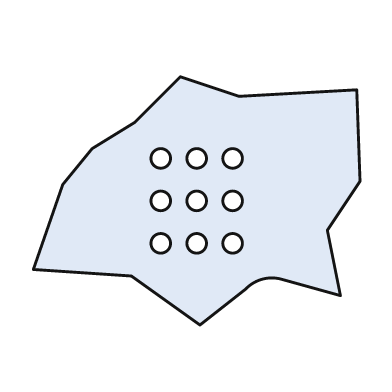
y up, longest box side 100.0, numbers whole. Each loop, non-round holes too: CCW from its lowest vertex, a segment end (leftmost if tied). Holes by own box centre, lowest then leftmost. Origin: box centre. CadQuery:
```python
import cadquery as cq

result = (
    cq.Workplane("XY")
    .moveTo(1.0, -38.0)
    .lineTo(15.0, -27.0)
    .threePointArc((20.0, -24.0), (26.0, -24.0))
    .lineTo(44.0, -29.0)
    .lineTo(40.0, -9.0)
    .lineTo(50.0, 6.0)
    .lineTo(49.0, 34.0)
    .lineTo(13.0, 32.0)
    .lineTo(-5.0, 38.0)
    .lineTo(-19.0, 24.0)
    .lineTo(-32.0, 16.0)
    .lineTo(-41.0, 5.0)
    .lineTo(-50.0, -21.0)
    .lineTo(-20.0, -23.0)
    .close()
    .moveTo(-11.0, -13.0)
    .circle(3.0)
    .moveTo(0.0, -13.0)
    .circle(3.0)
    .moveTo(11.0, -13.0)
    .circle(3.0)
    .moveTo(-11.0, 0.0)
    .circle(3.0)
    .moveTo(0.0, 0.0)
    .circle(3.0)
    .moveTo(11.0, 0.0)
    .circle(3.0)
    .moveTo(-11.0, 13.0)
    .circle(3.0)
    .moveTo(0.0, 13.0)
    .circle(3.0)
    .moveTo(11.0, 13.0)
    .circle(3.0)
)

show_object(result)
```